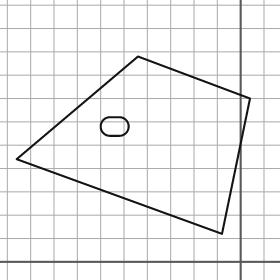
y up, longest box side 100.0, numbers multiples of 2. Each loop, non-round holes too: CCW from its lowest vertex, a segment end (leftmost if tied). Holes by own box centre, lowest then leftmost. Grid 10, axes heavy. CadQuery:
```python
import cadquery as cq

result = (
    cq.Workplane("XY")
    .moveTo(-8.0, 12.0)
    .lineTo(4.0, 70.0)
    .lineTo(-44.0, 88.0)
    .lineTo(-96.0, 44.0)
    .close()
    .moveTo(-56.0, 54.0)
    .lineTo(-52.0, 54.0)
    .threePointArc((-48.0, 58.0), (-52.0, 62.0))
    .lineTo(-56.0, 62.0)
    .threePointArc((-60.0, 58.0), (-56.0, 54.0))
    .close()
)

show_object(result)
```